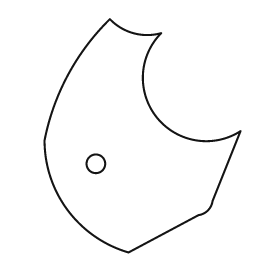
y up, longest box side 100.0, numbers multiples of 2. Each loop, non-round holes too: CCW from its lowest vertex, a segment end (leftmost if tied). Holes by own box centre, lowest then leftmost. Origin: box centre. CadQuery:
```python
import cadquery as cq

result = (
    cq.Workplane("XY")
    .moveTo(-6.0, -50.0)
    .lineTo(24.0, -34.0)
    .threePointArc((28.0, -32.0), (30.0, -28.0))
    .lineTo(42.0, 2.0)
    .threePointArc((6.0, 8.0), (8.0, 44.0))
    .threePointArc((-4.0, 44.0), (-14.0, 50.0))
    .threePointArc((-32.0, 26.0), (-42.0, -2.0))
    .threePointArc((-32.0, -32.0), (-6.0, -50.0))
    .close()
    .moveTo(-20.0, -12.0)
    .circle(4.0)
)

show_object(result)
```